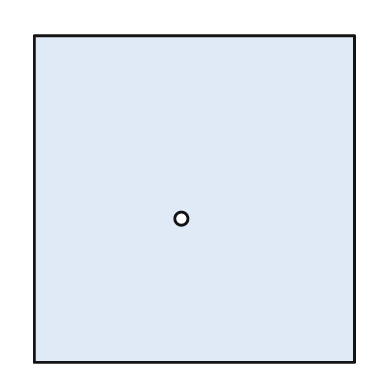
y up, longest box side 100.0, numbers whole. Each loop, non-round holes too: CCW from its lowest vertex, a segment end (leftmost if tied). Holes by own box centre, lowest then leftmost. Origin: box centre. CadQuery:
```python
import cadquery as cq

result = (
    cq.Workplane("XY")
    .moveTo(-49.0, -50.0)
    .lineTo(49.0, -50.0)
    .lineTo(49.0, 50.0)
    .lineTo(-49.0, 50.0)
    .close()
    .moveTo(-4.0, -6.0)
    .circle(2.0)
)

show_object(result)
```